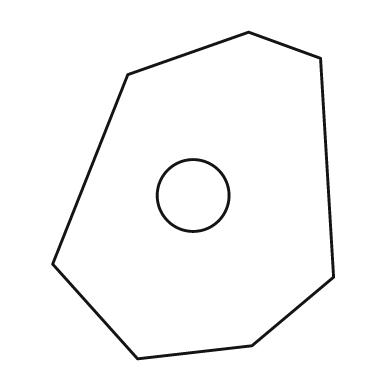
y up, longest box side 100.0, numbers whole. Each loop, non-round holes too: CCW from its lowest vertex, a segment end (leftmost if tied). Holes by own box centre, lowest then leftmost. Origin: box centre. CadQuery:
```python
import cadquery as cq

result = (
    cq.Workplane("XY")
    .moveTo(-17.0, -50.0)
    .lineTo(18.0, -46.0)
    .lineTo(43.0, -25.0)
    .lineTo(39.0, 42.0)
    .lineTo(17.0, 50.0)
    .lineTo(-20.0, 37.0)
    .lineTo(-43.0, -21.0)
    .close()
    .moveTo(0.0, 0.0)
    .circle(11.0)
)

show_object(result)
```